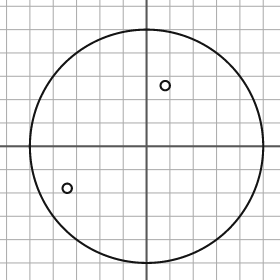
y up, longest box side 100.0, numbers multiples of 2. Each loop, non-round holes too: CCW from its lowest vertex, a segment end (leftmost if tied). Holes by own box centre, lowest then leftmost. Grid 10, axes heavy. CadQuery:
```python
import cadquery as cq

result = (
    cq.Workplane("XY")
    .moveTo(0.0, 0.0)
    .circle(50.0)
    .moveTo(-34.0, -18.0)
    .circle(2.0)
    .moveTo(8.0, 26.0)
    .circle(2.0)
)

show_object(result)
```